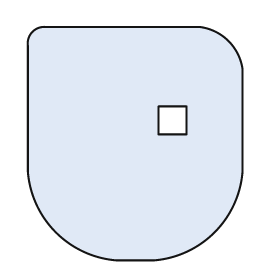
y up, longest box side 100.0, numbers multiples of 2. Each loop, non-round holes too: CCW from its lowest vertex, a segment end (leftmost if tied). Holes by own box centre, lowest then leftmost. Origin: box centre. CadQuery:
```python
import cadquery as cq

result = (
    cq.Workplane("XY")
    .moveTo(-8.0, -50.0)
    .lineTo(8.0, -50.0)
    .threePointArc((34.0, -38.0), (46.0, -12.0))
    .lineTo(46.0, 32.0)
    .threePointArc((40.0, 44.0), (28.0, 50.0))
    .lineTo(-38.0, 50.0)
    .threePointArc((-44.0, 48.0), (-46.0, 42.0))
    .lineTo(-46.0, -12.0)
    .threePointArc((-34.0, -38.0), (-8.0, -50.0))
    .close()
    .moveTo(10.0, 4.0)
    .lineTo(22.0, 4.0)
    .lineTo(22.0, 16.0)
    .lineTo(10.0, 16.0)
    .close()
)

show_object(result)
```